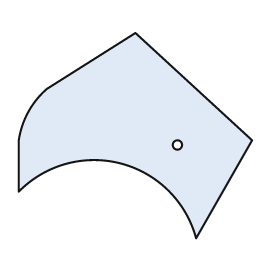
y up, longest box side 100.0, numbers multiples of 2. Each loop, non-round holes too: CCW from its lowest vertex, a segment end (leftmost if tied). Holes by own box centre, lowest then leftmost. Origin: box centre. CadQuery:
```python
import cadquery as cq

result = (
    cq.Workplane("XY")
    .moveTo(26.0, -44.0)
    .lineTo(50.0, -2.0)
    .lineTo(0.0, 44.0)
    .lineTo(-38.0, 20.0)
    .threePointArc((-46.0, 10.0), (-50.0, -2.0))
    .lineTo(-50.0, -24.0)
    .threePointArc((-6.0, -12.0), (26.0, -44.0))
    .close()
    .moveTo(18.0, -4.0)
    .circle(2.0)
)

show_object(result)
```